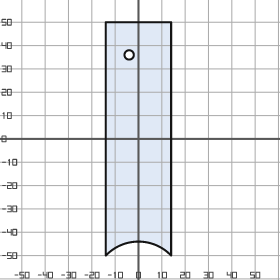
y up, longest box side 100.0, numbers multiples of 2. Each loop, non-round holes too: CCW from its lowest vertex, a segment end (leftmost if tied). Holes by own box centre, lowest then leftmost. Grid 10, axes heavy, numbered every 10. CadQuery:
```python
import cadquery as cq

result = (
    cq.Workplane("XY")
    .moveTo(-14.0, -50.0)
    .threePointArc((0.0, -44.0), (14.0, -50.0))
    .lineTo(14.0, 50.0)
    .lineTo(-14.0, 50.0)
    .close()
    .moveTo(-4.0, 36.0)
    .circle(2.0)
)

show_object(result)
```